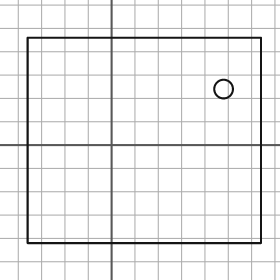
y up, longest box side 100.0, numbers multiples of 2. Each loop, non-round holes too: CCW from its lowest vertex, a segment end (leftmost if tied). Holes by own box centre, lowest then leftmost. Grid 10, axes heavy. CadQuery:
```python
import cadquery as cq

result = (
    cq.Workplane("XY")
    .moveTo(-36.0, -42.0)
    .lineTo(64.0, -42.0)
    .lineTo(64.0, 46.0)
    .lineTo(-36.0, 46.0)
    .close()
    .moveTo(48.0, 24.0)
    .circle(4.0)
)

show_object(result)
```